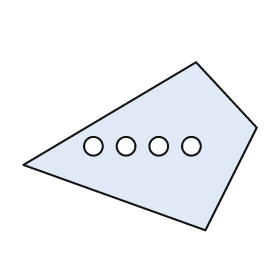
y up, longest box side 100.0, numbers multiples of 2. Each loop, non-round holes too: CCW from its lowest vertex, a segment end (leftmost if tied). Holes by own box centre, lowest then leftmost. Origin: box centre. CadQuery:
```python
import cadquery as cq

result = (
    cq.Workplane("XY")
    .moveTo(28.0, -36.0)
    .lineTo(50.0, 8.0)
    .lineTo(24.0, 36.0)
    .lineTo(-50.0, -8.0)
    .close()
    .moveTo(-20.0, 0.0)
    .circle(4.0)
    .moveTo(-6.0, 0.0)
    .circle(4.0)
    .moveTo(8.0, 0.0)
    .circle(4.0)
    .moveTo(22.0, 0.0)
    .circle(4.0)
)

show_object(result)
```